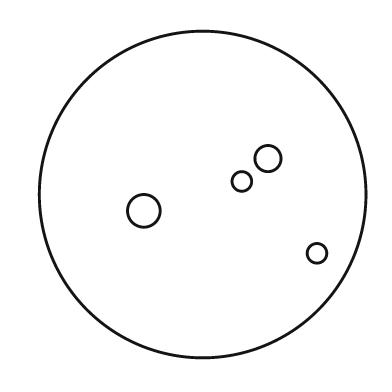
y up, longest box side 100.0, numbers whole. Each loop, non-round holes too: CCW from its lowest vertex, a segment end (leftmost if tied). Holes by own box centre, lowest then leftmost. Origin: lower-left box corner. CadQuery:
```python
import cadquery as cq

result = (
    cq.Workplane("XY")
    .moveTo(50.0, 50.0)
    .circle(50.0)
    .moveTo(85.0, 32.0)
    .circle(3.0)
    .moveTo(32.0, 45.0)
    .circle(5.0)
    .moveTo(62.0, 54.0)
    .circle(3.0)
    .moveTo(70.0, 61.0)
    .circle(4.0)
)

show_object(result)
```